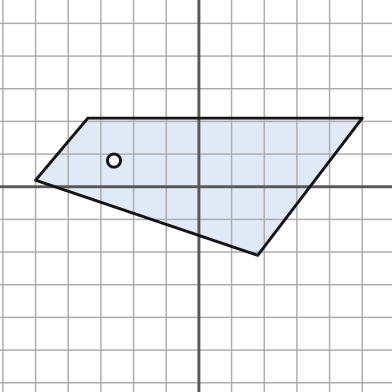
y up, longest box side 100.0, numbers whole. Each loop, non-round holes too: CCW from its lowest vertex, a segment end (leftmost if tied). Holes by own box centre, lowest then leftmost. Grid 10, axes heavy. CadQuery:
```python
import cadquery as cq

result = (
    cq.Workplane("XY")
    .moveTo(18.0, -21.0)
    .lineTo(50.0, 21.0)
    .lineTo(-34.0, 21.0)
    .lineTo(-50.0, 2.0)
    .close()
    .moveTo(-26.0, 8.0)
    .circle(2.0)
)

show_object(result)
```